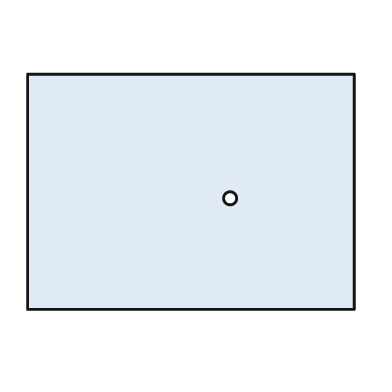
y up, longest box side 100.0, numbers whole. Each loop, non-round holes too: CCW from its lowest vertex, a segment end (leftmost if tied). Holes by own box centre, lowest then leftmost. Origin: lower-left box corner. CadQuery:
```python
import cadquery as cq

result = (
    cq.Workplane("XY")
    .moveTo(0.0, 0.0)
    .lineTo(100.0, 0.0)
    .lineTo(100.0, 72.0)
    .lineTo(0.0, 72.0)
    .close()
    .moveTo(62.0, 34.0)
    .circle(2.0)
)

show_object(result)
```